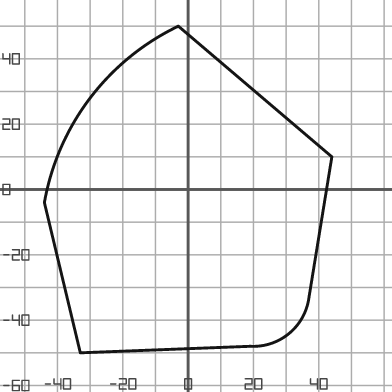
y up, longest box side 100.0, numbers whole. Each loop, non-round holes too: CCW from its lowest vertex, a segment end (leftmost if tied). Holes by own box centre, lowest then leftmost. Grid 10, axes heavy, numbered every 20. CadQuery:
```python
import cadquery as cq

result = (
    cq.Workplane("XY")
    .moveTo(-33.0, -50.0)
    .lineTo(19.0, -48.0)
    .threePointArc((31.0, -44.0), (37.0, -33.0))
    .lineTo(44.0, 10.0)
    .lineTo(-3.0, 50.0)
    .threePointArc((-30.0, 28.0), (-44.0, -4.0))
    .close()
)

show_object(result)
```